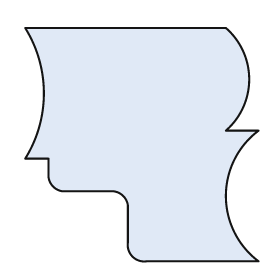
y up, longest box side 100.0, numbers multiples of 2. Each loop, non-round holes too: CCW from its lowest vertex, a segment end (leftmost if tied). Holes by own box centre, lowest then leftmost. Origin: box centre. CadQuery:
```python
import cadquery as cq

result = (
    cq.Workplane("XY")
    .moveTo(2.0, -50.0)
    .lineTo(50.0, -50.0)
    .threePointArc((36.0, -22.0), (50.0, 6.0))
    .lineTo(36.0, 6.0)
    .threePointArc((46.0, 28.0), (36.0, 50.0))
    .lineTo(-50.0, 50.0)
    .threePointArc((-42.0, 22.0), (-50.0, -6.0))
    .lineTo(-40.0, -6.0)
    .lineTo(-40.0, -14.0)
    .threePointArc((-38.0, -18.0), (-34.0, -20.0))
    .lineTo(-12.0, -20.0)
    .threePointArc((-8.0, -22.0), (-6.0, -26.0))
    .lineTo(-6.0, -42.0)
    .threePointArc((-4.0, -48.0), (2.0, -50.0))
    .close()
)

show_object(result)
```